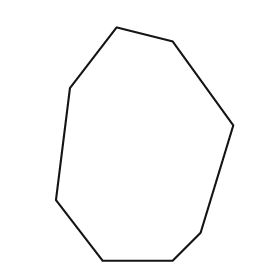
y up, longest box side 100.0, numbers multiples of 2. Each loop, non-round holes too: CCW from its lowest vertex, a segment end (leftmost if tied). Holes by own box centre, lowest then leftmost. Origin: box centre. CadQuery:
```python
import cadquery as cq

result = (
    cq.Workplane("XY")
    .moveTo(-18.0, -50.0)
    .lineTo(12.0, -50.0)
    .lineTo(24.0, -38.0)
    .lineTo(38.0, 8.0)
    .lineTo(12.0, 44.0)
    .lineTo(-12.0, 50.0)
    .lineTo(-32.0, 24.0)
    .lineTo(-38.0, -24.0)
    .close()
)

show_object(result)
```